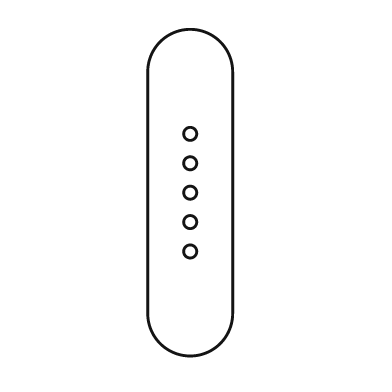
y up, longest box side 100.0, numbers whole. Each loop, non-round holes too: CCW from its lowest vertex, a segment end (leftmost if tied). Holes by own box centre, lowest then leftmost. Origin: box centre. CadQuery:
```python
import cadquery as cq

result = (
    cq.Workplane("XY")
    .moveTo(-13.0, -37.0)
    .threePointArc((0.0, -50.0), (13.0, -37.0))
    .lineTo(13.0, 37.0)
    .threePointArc((0.0, 50.0), (-13.0, 37.0))
    .close()
    .moveTo(0.0, -18.0)
    .circle(2.0)
    .moveTo(0.0, -9.0)
    .circle(2.0)
    .moveTo(0.0, 0.0)
    .circle(2.0)
    .moveTo(0.0, 9.0)
    .circle(2.0)
    .moveTo(0.0, 18.0)
    .circle(2.0)
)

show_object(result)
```